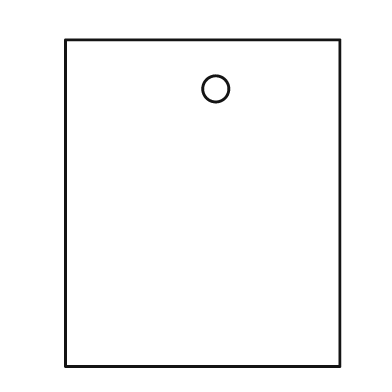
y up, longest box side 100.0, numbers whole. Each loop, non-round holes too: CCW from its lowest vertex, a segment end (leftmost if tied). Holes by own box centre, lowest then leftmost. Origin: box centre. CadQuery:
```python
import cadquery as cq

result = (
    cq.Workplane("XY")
    .moveTo(-42.0, -50.0)
    .lineTo(42.0, -50.0)
    .lineTo(42.0, 50.0)
    .lineTo(-42.0, 50.0)
    .close()
    .moveTo(4.0, 35.0)
    .circle(4.0)
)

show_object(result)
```